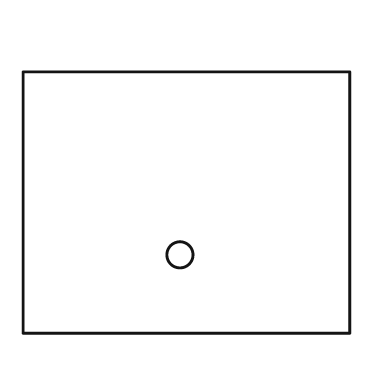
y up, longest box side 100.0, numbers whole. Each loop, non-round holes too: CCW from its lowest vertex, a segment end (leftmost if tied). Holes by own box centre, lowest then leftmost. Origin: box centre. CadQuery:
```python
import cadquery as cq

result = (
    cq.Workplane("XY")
    .moveTo(-50.0, -40.0)
    .lineTo(50.0, -40.0)
    .lineTo(50.0, 40.0)
    .lineTo(-50.0, 40.0)
    .close()
    .moveTo(-2.0, -16.0)
    .circle(4.0)
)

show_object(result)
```